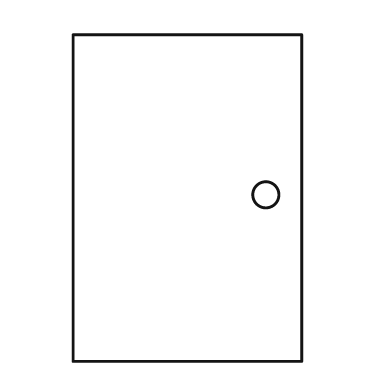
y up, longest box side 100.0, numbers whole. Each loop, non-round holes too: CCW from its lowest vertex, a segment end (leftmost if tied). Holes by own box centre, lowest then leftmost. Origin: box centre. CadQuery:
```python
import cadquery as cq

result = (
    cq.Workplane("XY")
    .moveTo(-35.0, -50.0)
    .lineTo(35.0, -50.0)
    .lineTo(35.0, 50.0)
    .lineTo(-35.0, 50.0)
    .close()
    .moveTo(24.0, 1.0)
    .circle(4.0)
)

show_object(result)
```